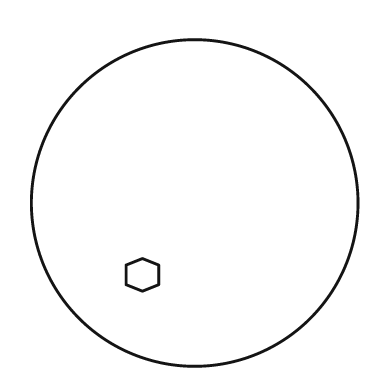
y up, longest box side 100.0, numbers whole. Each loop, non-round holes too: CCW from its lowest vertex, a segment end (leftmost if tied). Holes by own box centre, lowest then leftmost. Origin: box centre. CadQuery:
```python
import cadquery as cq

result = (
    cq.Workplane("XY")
    .moveTo(0.0, 0.0)
    .circle(50.0)
    .moveTo(-16.0, -27.0)
    .lineTo(-11.0, -25.0)
    .lineTo(-11.0, -19.0)
    .lineTo(-16.0, -17.0)
    .lineTo(-21.0, -19.0)
    .lineTo(-21.0, -25.0)
    .close()
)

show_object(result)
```